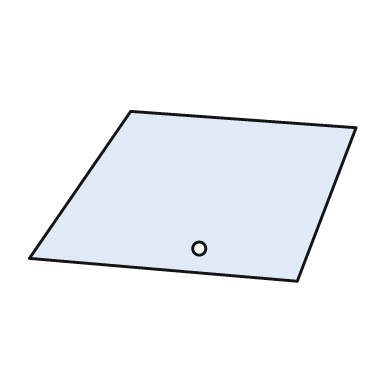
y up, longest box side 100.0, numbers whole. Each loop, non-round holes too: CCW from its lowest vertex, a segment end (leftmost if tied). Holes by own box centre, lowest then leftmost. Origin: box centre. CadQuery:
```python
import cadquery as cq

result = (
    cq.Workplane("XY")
    .moveTo(32.0, -26.0)
    .lineTo(50.0, 21.0)
    .lineTo(-19.0, 26.0)
    .lineTo(-50.0, -19.0)
    .close()
    .moveTo(2.0, -16.0)
    .circle(2.0)
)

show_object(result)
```